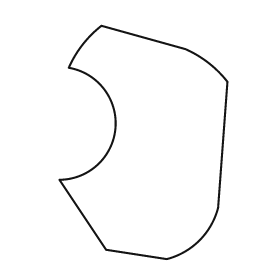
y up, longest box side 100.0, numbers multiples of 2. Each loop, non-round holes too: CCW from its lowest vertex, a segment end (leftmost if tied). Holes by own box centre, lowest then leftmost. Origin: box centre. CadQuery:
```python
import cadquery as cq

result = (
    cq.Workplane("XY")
    .moveTo(10.0, -50.0)
    .threePointArc((24.0, -42.0), (32.0, -28.0))
    .lineTo(36.0, 26.0)
    .threePointArc((28.0, 34.0), (18.0, 40.0))
    .lineTo(-18.0, 50.0)
    .threePointArc((-26.0, 42.0), (-32.0, 32.0))
    .threePointArc((-12.0, 6.0), (-36.0, -16.0))
    .lineTo(-16.0, -46.0)
    .close()
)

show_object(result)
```